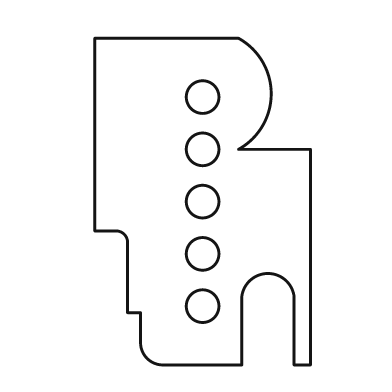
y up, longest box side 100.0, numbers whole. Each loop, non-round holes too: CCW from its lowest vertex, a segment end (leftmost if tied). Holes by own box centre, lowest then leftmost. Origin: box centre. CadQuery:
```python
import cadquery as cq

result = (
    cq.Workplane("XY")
    .moveTo(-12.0, -50.0)
    .lineTo(12.0, -50.0)
    .lineTo(12.0, -29.0)
    .threePointArc((20.0, -22.0), (28.0, -29.0))
    .lineTo(28.0, -50.0)
    .lineTo(33.0, -50.0)
    .lineTo(33.0, 16.0)
    .lineTo(11.0, 16.0)
    .threePointArc((21.0, 33.0), (11.0, 50.0))
    .lineTo(-33.0, 50.0)
    .lineTo(-33.0, -9.0)
    .lineTo(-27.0, -9.0)
    .threePointArc((-24.0, -10.0), (-23.0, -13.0))
    .lineTo(-23.0, -34.0)
    .lineTo(-19.0, -34.0)
    .lineTo(-19.0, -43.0)
    .threePointArc((-17.0, -48.0), (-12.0, -50.0))
    .close()
    .moveTo(0.0, -32.0)
    .circle(5.0)
    .moveTo(0.0, -16.0)
    .circle(5.0)
    .moveTo(0.0, 0.0)
    .circle(5.0)
    .moveTo(0.0, 16.0)
    .circle(5.0)
    .moveTo(0.0, 32.0)
    .circle(5.0)
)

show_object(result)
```